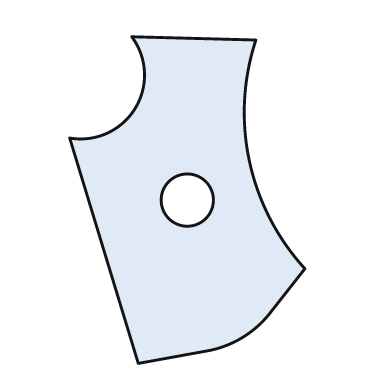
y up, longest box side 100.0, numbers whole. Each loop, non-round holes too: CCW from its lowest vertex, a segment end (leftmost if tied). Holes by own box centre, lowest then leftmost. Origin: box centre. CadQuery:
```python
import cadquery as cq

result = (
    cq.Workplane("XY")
    .moveTo(-15.0, -50.0)
    .lineTo(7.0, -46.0)
    .threePointArc((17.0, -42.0), (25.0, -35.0))
    .lineTo(36.0, -21.0)
    .threePointArc((19.0, 12.0), (21.0, 49.0))
    .lineTo(-17.0, 50.0)
    .threePointArc((-16.0, 28.0), (-36.0, 19.0))
    .close()
    .moveTo(0.0, 0.0)
    .circle(8.0)
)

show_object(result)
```